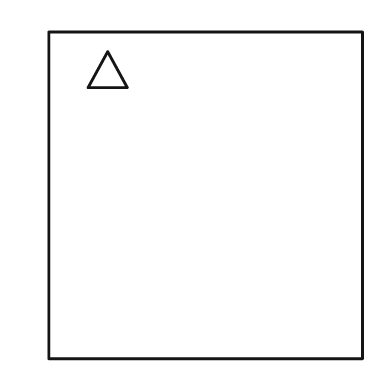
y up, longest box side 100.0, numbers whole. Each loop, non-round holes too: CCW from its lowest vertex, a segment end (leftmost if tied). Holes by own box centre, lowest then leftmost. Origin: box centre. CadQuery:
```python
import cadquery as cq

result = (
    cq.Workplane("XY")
    .moveTo(-48.0, -50.0)
    .lineTo(48.0, -50.0)
    .lineTo(48.0, 50.0)
    .lineTo(-48.0, 50.0)
    .close()
    .moveTo(-36.0, 33.0)
    .lineTo(-24.0, 33.0)
    .lineTo(-30.0, 44.0)
    .close()
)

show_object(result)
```